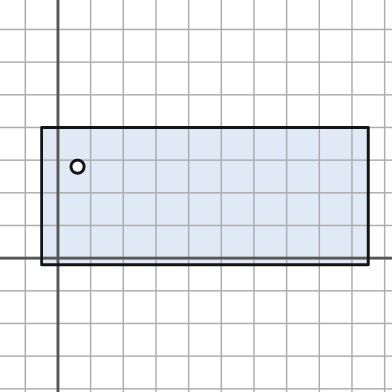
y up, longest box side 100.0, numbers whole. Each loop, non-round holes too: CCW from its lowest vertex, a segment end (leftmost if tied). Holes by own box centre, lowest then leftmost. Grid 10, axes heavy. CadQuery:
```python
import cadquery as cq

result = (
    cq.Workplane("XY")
    .moveTo(-5.0, -2.0)
    .lineTo(95.0, -2.0)
    .lineTo(95.0, 40.0)
    .lineTo(-5.0, 40.0)
    .close()
    .moveTo(6.0, 28.0)
    .circle(2.0)
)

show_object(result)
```